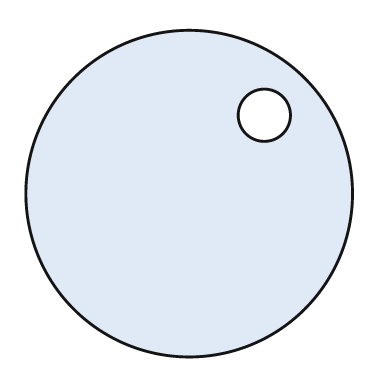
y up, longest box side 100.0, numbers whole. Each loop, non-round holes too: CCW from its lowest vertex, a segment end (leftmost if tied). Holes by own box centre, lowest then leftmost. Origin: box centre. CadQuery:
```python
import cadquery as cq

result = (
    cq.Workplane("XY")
    .moveTo(0.0, 0.0)
    .circle(50.0)
    .moveTo(23.0, 24.0)
    .circle(8.0)
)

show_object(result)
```